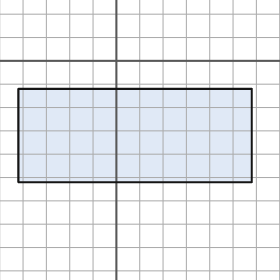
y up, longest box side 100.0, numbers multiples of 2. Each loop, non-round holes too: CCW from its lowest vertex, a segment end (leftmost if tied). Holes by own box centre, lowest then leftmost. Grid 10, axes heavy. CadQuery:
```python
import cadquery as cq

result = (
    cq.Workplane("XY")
    .moveTo(-42.0, -52.0)
    .lineTo(58.0, -52.0)
    .lineTo(58.0, -12.0)
    .lineTo(-42.0, -12.0)
    .close()
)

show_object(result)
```